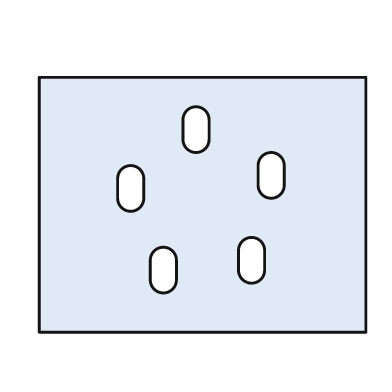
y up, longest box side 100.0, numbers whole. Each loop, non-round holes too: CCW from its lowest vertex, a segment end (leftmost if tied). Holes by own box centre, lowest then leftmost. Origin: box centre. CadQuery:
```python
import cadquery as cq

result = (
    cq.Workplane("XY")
    .moveTo(-50.0, -39.0)
    .lineTo(50.0, -39.0)
    .lineTo(50.0, 39.0)
    .lineTo(-50.0, 39.0)
    .close()
    .moveTo(-16.0, -23.0)
    .threePointArc((-12.0, -27.0), (-8.0, -23.0))
    .lineTo(-8.0, -17.0)
    .threePointArc((-12.0, -13.0), (-16.0, -17.0))
    .close()
    .moveTo(11.0, -20.0)
    .threePointArc((15.0, -24.0), (19.0, -20.0))
    .lineTo(19.0, -14.0)
    .threePointArc((15.0, -10.0), (11.0, -14.0))
    .close()
    .moveTo(-26.0, 2.0)
    .threePointArc((-22.0, -2.0), (-18.0, 2.0))
    .lineTo(-18.0, 8.0)
    .threePointArc((-22.0, 12.0), (-26.0, 8.0))
    .close()
    .moveTo(17.0, 6.0)
    .threePointArc((21.0, 2.0), (25.0, 6.0))
    .lineTo(25.0, 12.0)
    .threePointArc((21.0, 16.0), (17.0, 12.0))
    .close()
    .moveTo(-6.0, 20.0)
    .threePointArc((-2.0, 16.0), (2.0, 20.0))
    .lineTo(2.0, 26.0)
    .threePointArc((-2.0, 30.0), (-6.0, 26.0))
    .close()
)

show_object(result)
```